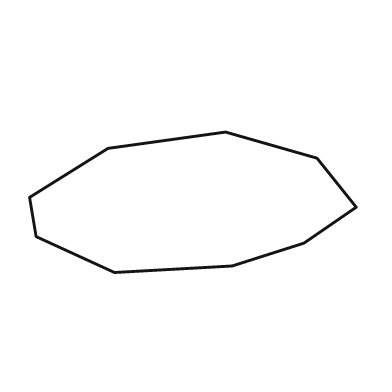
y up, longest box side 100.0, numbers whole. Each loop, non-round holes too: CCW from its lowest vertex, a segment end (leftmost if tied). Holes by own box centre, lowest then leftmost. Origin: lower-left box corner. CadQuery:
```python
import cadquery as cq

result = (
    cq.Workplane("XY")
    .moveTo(26.0, 0.0)
    .lineTo(62.0, 2.0)
    .lineTo(84.0, 9.0)
    .lineTo(100.0, 20.0)
    .lineTo(88.0, 35.0)
    .lineTo(60.0, 43.0)
    .lineTo(24.0, 38.0)
    .lineTo(0.0, 23.0)
    .lineTo(2.0, 11.0)
    .close()
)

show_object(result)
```